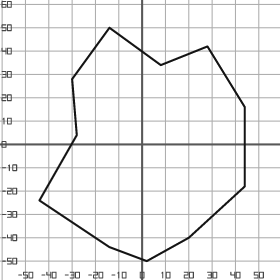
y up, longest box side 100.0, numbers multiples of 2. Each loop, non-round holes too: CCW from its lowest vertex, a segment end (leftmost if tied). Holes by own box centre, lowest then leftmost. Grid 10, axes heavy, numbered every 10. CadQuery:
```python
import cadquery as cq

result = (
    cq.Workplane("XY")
    .moveTo(2.0, -50.0)
    .lineTo(20.0, -40.0)
    .lineTo(44.0, -18.0)
    .lineTo(44.0, 16.0)
    .lineTo(28.0, 42.0)
    .lineTo(8.0, 34.0)
    .lineTo(-14.0, 50.0)
    .lineTo(-30.0, 28.0)
    .lineTo(-28.0, 4.0)
    .lineTo(-44.0, -24.0)
    .lineTo(-14.0, -44.0)
    .close()
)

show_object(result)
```